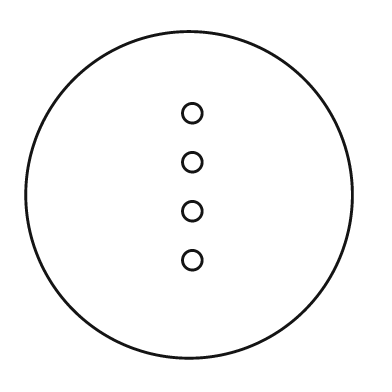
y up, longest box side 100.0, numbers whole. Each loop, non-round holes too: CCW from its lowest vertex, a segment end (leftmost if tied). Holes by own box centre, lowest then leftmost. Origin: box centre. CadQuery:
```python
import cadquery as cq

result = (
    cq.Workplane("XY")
    .moveTo(0.0, 0.0)
    .circle(50.0)
    .moveTo(1.0, -20.0)
    .circle(3.0)
    .moveTo(1.0, -5.0)
    .circle(3.0)
    .moveTo(1.0, 10.0)
    .circle(3.0)
    .moveTo(1.0, 25.0)
    .circle(3.0)
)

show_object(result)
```